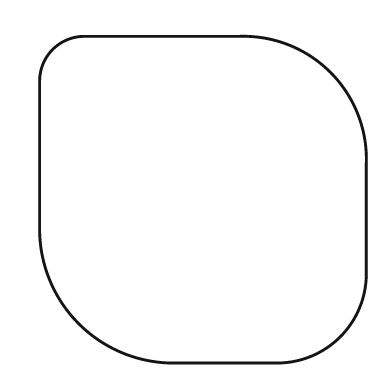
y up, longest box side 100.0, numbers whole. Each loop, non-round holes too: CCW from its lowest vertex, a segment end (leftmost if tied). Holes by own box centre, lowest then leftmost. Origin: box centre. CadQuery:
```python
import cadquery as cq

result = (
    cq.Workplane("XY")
    .moveTo(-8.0, -50.0)
    .lineTo(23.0, -50.0)
    .threePointArc((42.0, -42.0), (50.0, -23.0))
    .lineTo(50.0, 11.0)
    .threePointArc((39.0, 39.0), (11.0, 50.0))
    .lineTo(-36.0, 50.0)
    .threePointArc((-46.0, 46.0), (-50.0, 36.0))
    .lineTo(-50.0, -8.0)
    .threePointArc((-38.0, -38.0), (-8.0, -50.0))
    .close()
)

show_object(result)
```